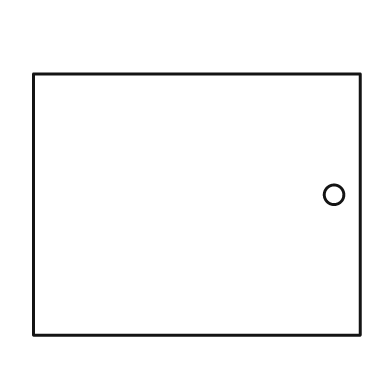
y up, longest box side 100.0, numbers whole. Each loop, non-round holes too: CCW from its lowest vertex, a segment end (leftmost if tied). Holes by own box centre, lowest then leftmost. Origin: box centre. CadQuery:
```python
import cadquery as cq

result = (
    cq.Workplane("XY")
    .moveTo(-50.0, -40.0)
    .lineTo(50.0, -40.0)
    .lineTo(50.0, 40.0)
    .lineTo(-50.0, 40.0)
    .close()
    .moveTo(42.0, 3.0)
    .circle(3.0)
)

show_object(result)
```